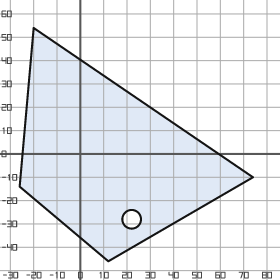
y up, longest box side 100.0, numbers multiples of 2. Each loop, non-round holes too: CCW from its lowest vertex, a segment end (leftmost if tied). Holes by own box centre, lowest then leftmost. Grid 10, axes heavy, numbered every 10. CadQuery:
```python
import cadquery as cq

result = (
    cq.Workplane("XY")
    .moveTo(12.0, -46.0)
    .lineTo(74.0, -10.0)
    .lineTo(-20.0, 54.0)
    .lineTo(-26.0, -14.0)
    .close()
    .moveTo(22.0, -28.0)
    .circle(4.0)
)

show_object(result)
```